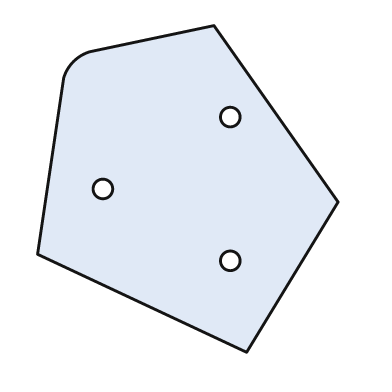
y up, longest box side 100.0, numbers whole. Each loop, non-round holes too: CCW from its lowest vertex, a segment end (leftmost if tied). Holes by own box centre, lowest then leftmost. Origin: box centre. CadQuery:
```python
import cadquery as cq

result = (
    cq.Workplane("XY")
    .moveTo(18.0, -50.0)
    .lineTo(46.0, -4.0)
    .lineTo(8.0, 50.0)
    .lineTo(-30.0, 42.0)
    .threePointArc((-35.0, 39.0), (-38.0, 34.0))
    .lineTo(-46.0, -20.0)
    .close()
    .moveTo(13.0, -22.0)
    .circle(3.0)
    .moveTo(-26.0, 0.0)
    .circle(3.0)
    .moveTo(13.0, 22.0)
    .circle(3.0)
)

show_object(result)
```